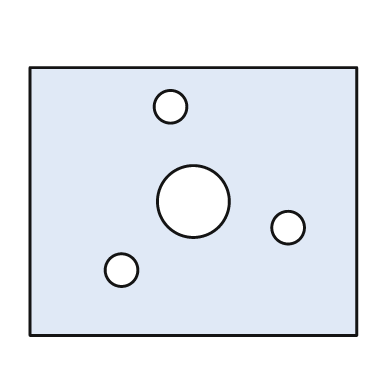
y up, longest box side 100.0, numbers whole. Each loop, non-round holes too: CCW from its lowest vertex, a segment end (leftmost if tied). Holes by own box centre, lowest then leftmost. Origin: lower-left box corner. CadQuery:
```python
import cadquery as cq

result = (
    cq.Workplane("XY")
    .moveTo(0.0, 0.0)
    .lineTo(100.0, 0.0)
    .lineTo(100.0, 82.0)
    .lineTo(0.0, 82.0)
    .close()
    .moveTo(28.0, 20.0)
    .circle(5.0)
    .moveTo(79.0, 33.0)
    .circle(5.0)
    .moveTo(50.0, 41.0)
    .circle(11.0)
    .moveTo(43.0, 70.0)
    .circle(5.0)
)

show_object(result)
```